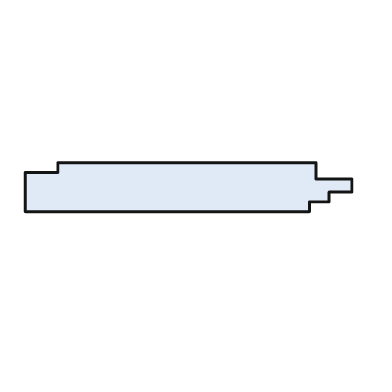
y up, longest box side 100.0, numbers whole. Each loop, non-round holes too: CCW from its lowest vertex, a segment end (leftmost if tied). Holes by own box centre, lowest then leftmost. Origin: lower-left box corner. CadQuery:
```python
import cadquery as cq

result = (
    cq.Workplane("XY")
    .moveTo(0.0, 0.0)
    .lineTo(87.0, 0.0)
    .lineTo(87.0, 3.0)
    .lineTo(93.0, 3.0)
    .lineTo(93.0, 6.0)
    .lineTo(100.0, 6.0)
    .lineTo(100.0, 10.0)
    .lineTo(89.0, 10.0)
    .lineTo(89.0, 15.0)
    .lineTo(10.0, 15.0)
    .lineTo(10.0, 12.0)
    .lineTo(0.0, 12.0)
    .close()
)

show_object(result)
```